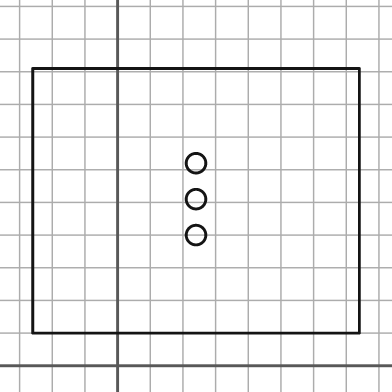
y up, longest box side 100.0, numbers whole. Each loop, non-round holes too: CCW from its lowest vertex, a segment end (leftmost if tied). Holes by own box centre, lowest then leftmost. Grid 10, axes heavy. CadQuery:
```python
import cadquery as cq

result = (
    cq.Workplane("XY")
    .moveTo(-26.0, 10.0)
    .lineTo(74.0, 10.0)
    .lineTo(74.0, 91.0)
    .lineTo(-26.0, 91.0)
    .close()
    .moveTo(24.0, 40.0)
    .circle(3.0)
    .moveTo(24.0, 51.0)
    .circle(3.0)
    .moveTo(24.0, 62.0)
    .circle(3.0)
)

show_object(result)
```